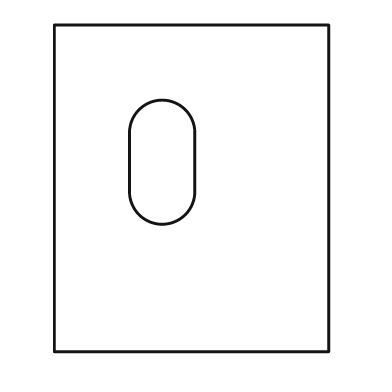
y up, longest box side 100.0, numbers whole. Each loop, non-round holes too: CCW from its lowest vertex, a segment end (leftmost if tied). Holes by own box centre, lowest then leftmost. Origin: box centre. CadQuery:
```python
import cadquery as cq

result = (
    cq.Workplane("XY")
    .moveTo(-42.0, -50.0)
    .lineTo(42.0, -50.0)
    .lineTo(42.0, 50.0)
    .lineTo(-42.0, 50.0)
    .close()
    .moveTo(-19.0, -1.0)
    .threePointArc((-9.0, -11.0), (1.0, -1.0))
    .lineTo(1.0, 17.0)
    .threePointArc((-9.0, 27.0), (-19.0, 17.0))
    .close()
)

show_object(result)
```